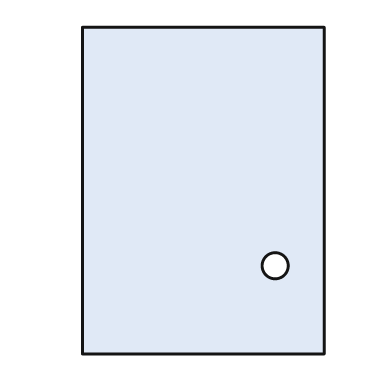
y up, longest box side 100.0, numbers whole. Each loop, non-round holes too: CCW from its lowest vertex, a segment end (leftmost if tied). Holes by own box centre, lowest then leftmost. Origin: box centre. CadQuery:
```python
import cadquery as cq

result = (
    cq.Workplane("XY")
    .moveTo(-37.0, -50.0)
    .lineTo(37.0, -50.0)
    .lineTo(37.0, 50.0)
    .lineTo(-37.0, 50.0)
    .close()
    .moveTo(22.0, -23.0)
    .circle(4.0)
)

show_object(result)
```